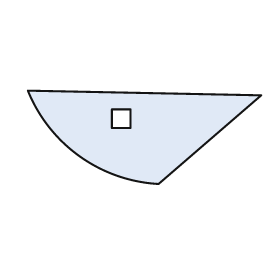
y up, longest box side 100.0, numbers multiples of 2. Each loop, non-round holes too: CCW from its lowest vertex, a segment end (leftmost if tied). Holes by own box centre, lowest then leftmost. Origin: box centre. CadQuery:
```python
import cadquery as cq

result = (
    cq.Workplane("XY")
    .moveTo(6.0, -20.0)
    .lineTo(50.0, 18.0)
    .lineTo(-50.0, 20.0)
    .threePointArc((-28.0, -8.0), (6.0, -20.0))
    .close()
    .moveTo(-14.0, 4.0)
    .lineTo(-6.0, 4.0)
    .lineTo(-6.0, 12.0)
    .lineTo(-14.0, 12.0)
    .close()
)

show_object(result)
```